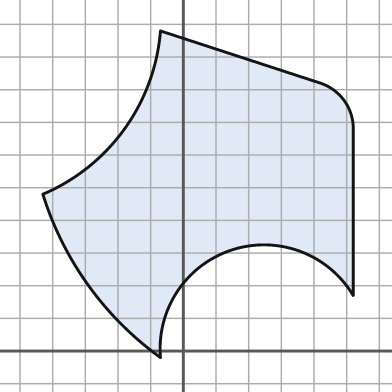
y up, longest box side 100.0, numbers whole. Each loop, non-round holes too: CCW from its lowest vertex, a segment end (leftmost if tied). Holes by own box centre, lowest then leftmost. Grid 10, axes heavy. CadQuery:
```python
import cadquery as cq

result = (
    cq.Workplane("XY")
    .moveTo(-7.0, -2.0)
    .threePointArc((15.0, 31.0), (52.0, 17.0))
    .lineTo(52.0, 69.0)
    .threePointArc((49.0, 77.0), (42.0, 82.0))
    .lineTo(-7.0, 98.0)
    .threePointArc((-18.0, 68.0), (-43.0, 48.0))
    .threePointArc((-29.0, 20.0), (-7.0, -2.0))
    .close()
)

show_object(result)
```